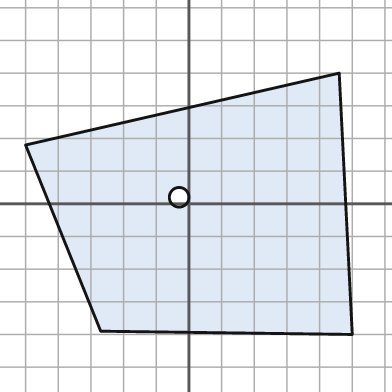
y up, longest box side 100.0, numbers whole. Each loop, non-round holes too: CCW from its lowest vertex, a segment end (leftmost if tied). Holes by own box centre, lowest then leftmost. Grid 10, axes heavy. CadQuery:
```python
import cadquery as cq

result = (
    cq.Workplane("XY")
    .moveTo(50.0, -40.0)
    .lineTo(46.0, 40.0)
    .lineTo(-50.0, 18.0)
    .lineTo(-27.0, -39.0)
    .close()
    .moveTo(-3.0, 2.0)
    .circle(3.0)
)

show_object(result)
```